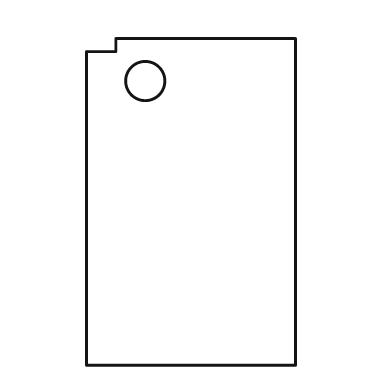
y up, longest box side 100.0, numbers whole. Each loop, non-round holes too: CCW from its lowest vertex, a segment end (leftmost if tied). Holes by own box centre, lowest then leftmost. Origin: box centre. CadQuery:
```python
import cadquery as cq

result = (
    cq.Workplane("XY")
    .moveTo(-32.0, -50.0)
    .lineTo(32.0, -50.0)
    .lineTo(32.0, 50.0)
    .lineTo(-23.0, 50.0)
    .lineTo(-23.0, 46.0)
    .lineTo(-32.0, 46.0)
    .close()
    .moveTo(-14.0, 37.0)
    .circle(6.0)
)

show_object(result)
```